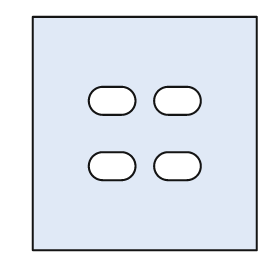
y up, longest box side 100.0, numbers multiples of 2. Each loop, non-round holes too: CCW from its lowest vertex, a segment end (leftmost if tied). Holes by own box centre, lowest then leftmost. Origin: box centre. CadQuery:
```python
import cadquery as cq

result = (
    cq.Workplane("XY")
    .moveTo(-48.0, -50.0)
    .lineTo(48.0, -50.0)
    .lineTo(48.0, 50.0)
    .lineTo(-48.0, 50.0)
    .close()
    .moveTo(-18.0, -20.0)
    .lineTo(-10.0, -20.0)
    .threePointArc((-4.0, -14.0), (-10.0, -8.0))
    .lineTo(-18.0, -8.0)
    .threePointArc((-24.0, -14.0), (-18.0, -20.0))
    .close()
    .moveTo(10.0, -20.0)
    .lineTo(18.0, -20.0)
    .threePointArc((24.0, -14.0), (18.0, -8.0))
    .lineTo(10.0, -8.0)
    .threePointArc((4.0, -14.0), (10.0, -20.0))
    .close()
    .moveTo(-18.0, 8.0)
    .lineTo(-10.0, 8.0)
    .threePointArc((-4.0, 14.0), (-10.0, 20.0))
    .lineTo(-18.0, 20.0)
    .threePointArc((-24.0, 14.0), (-18.0, 8.0))
    .close()
    .moveTo(10.0, 8.0)
    .lineTo(18.0, 8.0)
    .threePointArc((24.0, 14.0), (18.0, 20.0))
    .lineTo(10.0, 20.0)
    .threePointArc((4.0, 14.0), (10.0, 8.0))
    .close()
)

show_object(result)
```